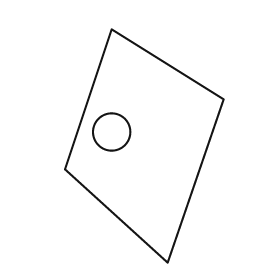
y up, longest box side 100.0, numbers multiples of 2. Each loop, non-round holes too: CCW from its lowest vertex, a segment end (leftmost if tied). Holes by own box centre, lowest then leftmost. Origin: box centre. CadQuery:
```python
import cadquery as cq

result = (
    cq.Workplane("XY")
    .moveTo(10.0, -50.0)
    .lineTo(34.0, 20.0)
    .lineTo(-14.0, 50.0)
    .lineTo(-34.0, -10.0)
    .close()
    .moveTo(-14.0, 6.0)
    .circle(8.0)
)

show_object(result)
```